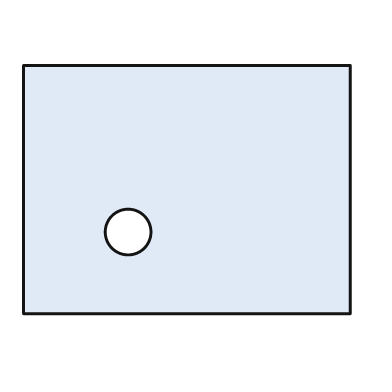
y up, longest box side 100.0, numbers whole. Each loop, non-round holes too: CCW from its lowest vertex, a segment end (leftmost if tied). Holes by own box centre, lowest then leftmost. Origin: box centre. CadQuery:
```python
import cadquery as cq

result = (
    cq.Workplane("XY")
    .moveTo(-50.0, -38.0)
    .lineTo(50.0, -38.0)
    .lineTo(50.0, 38.0)
    .lineTo(-50.0, 38.0)
    .close()
    .moveTo(-18.0, -13.0)
    .circle(7.0)
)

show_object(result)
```